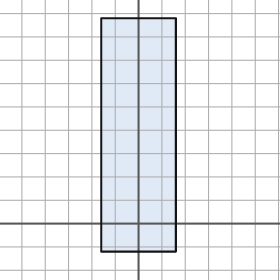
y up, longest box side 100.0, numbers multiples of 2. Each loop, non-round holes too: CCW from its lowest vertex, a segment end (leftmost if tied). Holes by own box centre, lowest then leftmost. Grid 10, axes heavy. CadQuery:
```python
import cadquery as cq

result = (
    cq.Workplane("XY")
    .moveTo(-16.0, -12.0)
    .lineTo(16.0, -12.0)
    .lineTo(16.0, 88.0)
    .lineTo(-16.0, 88.0)
    .close()
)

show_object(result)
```